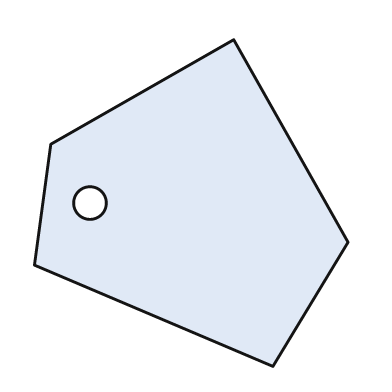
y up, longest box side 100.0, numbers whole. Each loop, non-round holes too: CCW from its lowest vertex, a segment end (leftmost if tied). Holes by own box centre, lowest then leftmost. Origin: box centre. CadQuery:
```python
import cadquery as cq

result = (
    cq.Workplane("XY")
    .moveTo(25.0, -50.0)
    .lineTo(48.0, -12.0)
    .lineTo(13.0, 50.0)
    .lineTo(-43.0, 18.0)
    .lineTo(-48.0, -19.0)
    .close()
    .moveTo(-31.0, 0.0)
    .circle(5.0)
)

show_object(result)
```